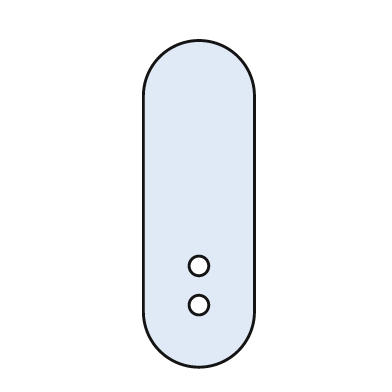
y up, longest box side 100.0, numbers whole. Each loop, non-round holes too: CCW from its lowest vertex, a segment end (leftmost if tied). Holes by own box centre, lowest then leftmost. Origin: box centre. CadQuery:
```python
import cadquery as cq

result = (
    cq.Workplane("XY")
    .moveTo(-17.0, -33.0)
    .threePointArc((0.0, -50.0), (17.0, -33.0))
    .lineTo(17.0, 33.0)
    .threePointArc((0.0, 50.0), (-17.0, 33.0))
    .close()
    .moveTo(0.0, -31.0)
    .circle(3.0)
    .moveTo(0.0, -19.0)
    .circle(3.0)
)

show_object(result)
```